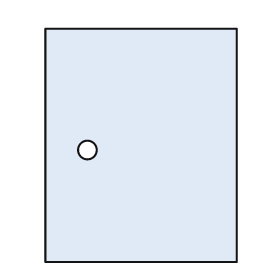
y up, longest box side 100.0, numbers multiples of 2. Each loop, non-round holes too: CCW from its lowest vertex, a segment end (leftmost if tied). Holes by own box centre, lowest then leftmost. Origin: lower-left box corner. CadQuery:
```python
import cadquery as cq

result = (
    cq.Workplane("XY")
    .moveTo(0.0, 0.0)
    .lineTo(82.0, 0.0)
    .lineTo(82.0, 100.0)
    .lineTo(0.0, 100.0)
    .close()
    .moveTo(18.0, 48.0)
    .circle(4.0)
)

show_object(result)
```